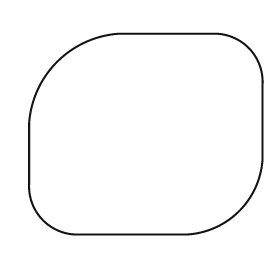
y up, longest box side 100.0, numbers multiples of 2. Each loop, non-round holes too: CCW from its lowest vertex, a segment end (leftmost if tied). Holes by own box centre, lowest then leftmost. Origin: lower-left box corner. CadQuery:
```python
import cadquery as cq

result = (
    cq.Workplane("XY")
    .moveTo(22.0, 0.0)
    .lineTo(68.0, 0.0)
    .threePointArc((90.0, 10.0), (100.0, 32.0))
    .lineTo(100.0, 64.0)
    .threePointArc((94.0, 80.0), (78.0, 86.0))
    .lineTo(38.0, 86.0)
    .threePointArc((12.0, 74.0), (0.0, 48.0))
    .lineTo(0.0, 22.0)
    .threePointArc((6.0, 6.0), (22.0, 0.0))
    .close()
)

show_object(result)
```